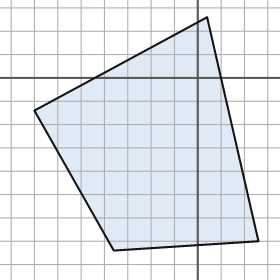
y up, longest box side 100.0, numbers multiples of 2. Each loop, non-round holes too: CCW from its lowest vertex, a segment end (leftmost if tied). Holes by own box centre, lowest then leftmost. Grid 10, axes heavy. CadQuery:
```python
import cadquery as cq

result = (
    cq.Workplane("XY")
    .moveTo(-36.0, -74.0)
    .lineTo(26.0, -70.0)
    .lineTo(4.0, 26.0)
    .lineTo(-70.0, -14.0)
    .close()
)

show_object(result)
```